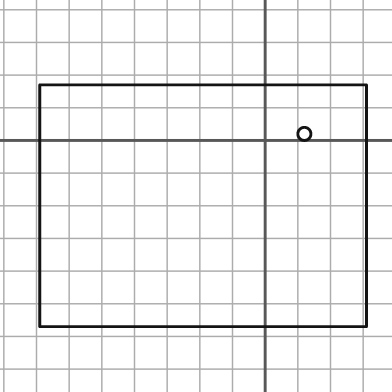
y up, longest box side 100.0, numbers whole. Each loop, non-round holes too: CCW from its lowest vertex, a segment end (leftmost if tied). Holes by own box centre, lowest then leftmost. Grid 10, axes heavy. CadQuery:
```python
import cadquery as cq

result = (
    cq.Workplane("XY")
    .moveTo(-69.0, -57.0)
    .lineTo(31.0, -57.0)
    .lineTo(31.0, 17.0)
    .lineTo(-69.0, 17.0)
    .close()
    .moveTo(12.0, 2.0)
    .circle(2.0)
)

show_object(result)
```